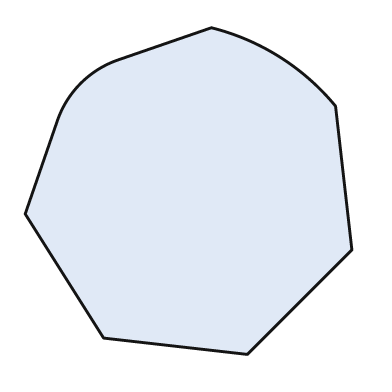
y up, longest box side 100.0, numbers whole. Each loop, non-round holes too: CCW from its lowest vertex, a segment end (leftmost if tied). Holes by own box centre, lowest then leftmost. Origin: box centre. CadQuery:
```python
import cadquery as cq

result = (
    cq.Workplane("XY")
    .moveTo(18.0, -50.0)
    .lineTo(50.0, -18.0)
    .lineTo(45.0, 26.0)
    .threePointArc((28.0, 41.0), (7.0, 50.0))
    .lineTo(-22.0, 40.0)
    .threePointArc((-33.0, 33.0), (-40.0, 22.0))
    .lineTo(-50.0, -7.0)
    .lineTo(-26.0, -45.0)
    .close()
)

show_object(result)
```